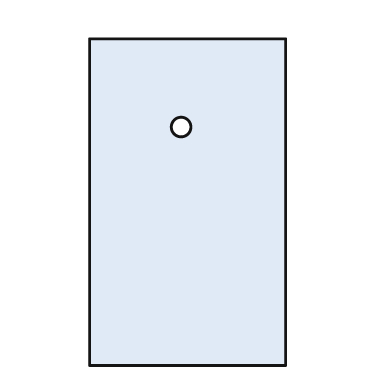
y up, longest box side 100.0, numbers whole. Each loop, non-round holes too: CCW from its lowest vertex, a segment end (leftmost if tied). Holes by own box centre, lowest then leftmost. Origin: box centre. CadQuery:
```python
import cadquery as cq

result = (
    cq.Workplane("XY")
    .moveTo(-30.0, -50.0)
    .lineTo(30.0, -50.0)
    .lineTo(30.0, 50.0)
    .lineTo(-30.0, 50.0)
    .close()
    .moveTo(-2.0, 23.0)
    .circle(3.0)
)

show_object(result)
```